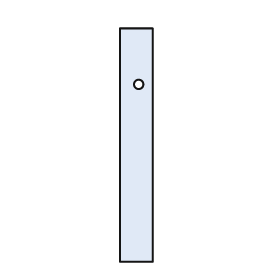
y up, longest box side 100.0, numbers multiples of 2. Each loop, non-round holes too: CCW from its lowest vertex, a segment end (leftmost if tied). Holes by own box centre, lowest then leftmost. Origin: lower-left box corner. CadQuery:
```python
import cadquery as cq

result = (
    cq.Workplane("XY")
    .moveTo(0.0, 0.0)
    .lineTo(14.0, 0.0)
    .lineTo(14.0, 100.0)
    .lineTo(0.0, 100.0)
    .close()
    .moveTo(8.0, 76.0)
    .circle(2.0)
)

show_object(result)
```